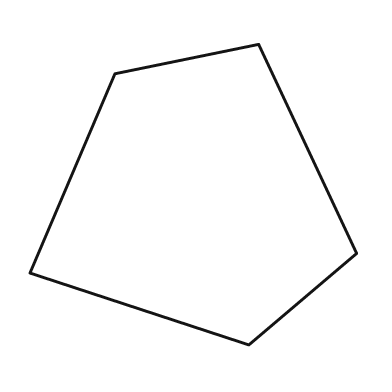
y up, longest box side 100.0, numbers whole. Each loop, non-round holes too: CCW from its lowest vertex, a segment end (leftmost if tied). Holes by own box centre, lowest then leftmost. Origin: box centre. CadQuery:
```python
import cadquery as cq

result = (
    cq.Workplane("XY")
    .moveTo(17.0, -46.0)
    .lineTo(50.0, -18.0)
    .lineTo(20.0, 46.0)
    .lineTo(-24.0, 37.0)
    .lineTo(-50.0, -24.0)
    .close()
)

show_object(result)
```